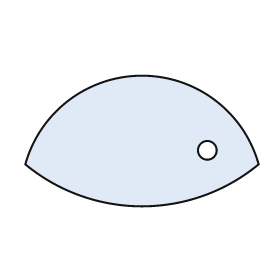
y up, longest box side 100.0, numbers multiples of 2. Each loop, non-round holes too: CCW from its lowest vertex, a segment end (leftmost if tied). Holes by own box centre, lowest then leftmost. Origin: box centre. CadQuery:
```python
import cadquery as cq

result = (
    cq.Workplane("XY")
    .moveTo(-50.0, -10.0)
    .threePointArc((0.0, -28.0), (50.0, -10.0))
    .threePointArc((0.0, 28.0), (-50.0, -10.0))
    .close()
    .moveTo(28.0, -4.0)
    .circle(4.0)
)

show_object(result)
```